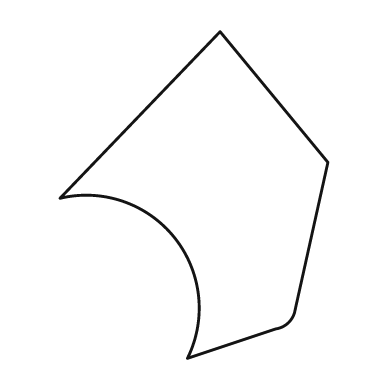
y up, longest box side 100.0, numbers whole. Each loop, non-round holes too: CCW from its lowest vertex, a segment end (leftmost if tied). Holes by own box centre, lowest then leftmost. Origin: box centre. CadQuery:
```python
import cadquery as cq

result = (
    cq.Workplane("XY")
    .moveTo(-2.0, -50.0)
    .lineTo(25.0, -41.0)
    .threePointArc((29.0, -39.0), (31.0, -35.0))
    .lineTo(41.0, 10.0)
    .lineTo(8.0, 50.0)
    .lineTo(-41.0, -1.0)
    .threePointArc((-6.0, -13.0), (-2.0, -50.0))
    .close()
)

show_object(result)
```